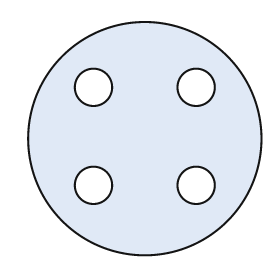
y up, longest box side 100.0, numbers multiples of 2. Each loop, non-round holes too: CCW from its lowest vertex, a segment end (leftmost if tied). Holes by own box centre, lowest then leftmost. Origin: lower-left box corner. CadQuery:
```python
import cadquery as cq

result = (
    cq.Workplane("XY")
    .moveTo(50.0, 50.0)
    .circle(50.0)
    .moveTo(28.0, 30.0)
    .circle(8.0)
    .moveTo(72.0, 30.0)
    .circle(8.0)
    .moveTo(28.0, 72.0)
    .circle(8.0)
    .moveTo(72.0, 72.0)
    .circle(8.0)
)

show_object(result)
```